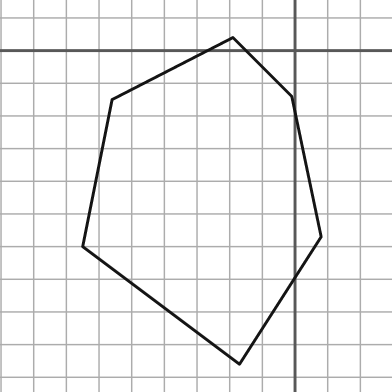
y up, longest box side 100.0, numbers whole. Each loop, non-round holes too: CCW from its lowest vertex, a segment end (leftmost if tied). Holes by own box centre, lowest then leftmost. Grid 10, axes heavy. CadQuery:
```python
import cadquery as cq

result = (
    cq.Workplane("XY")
    .moveTo(-17.0, -96.0)
    .lineTo(8.0, -57.0)
    .lineTo(-1.0, -14.0)
    .lineTo(-19.0, 4.0)
    .lineTo(-56.0, -15.0)
    .lineTo(-65.0, -60.0)
    .close()
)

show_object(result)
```